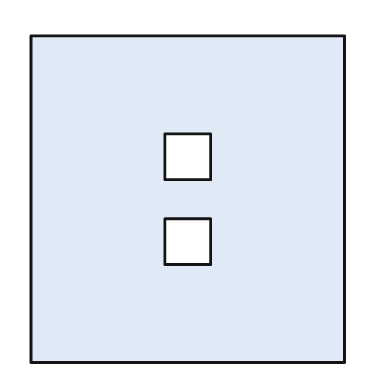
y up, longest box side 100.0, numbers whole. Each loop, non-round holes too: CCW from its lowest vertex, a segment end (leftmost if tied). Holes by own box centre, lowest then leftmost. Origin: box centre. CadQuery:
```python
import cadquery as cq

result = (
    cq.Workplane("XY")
    .moveTo(-48.0, -50.0)
    .lineTo(48.0, -50.0)
    .lineTo(48.0, 50.0)
    .lineTo(-48.0, 50.0)
    .close()
    .moveTo(-7.0, -20.0)
    .lineTo(7.0, -20.0)
    .lineTo(7.0, -6.0)
    .lineTo(-7.0, -6.0)
    .close()
    .moveTo(-7.0, 6.0)
    .lineTo(7.0, 6.0)
    .lineTo(7.0, 20.0)
    .lineTo(-7.0, 20.0)
    .close()
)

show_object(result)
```